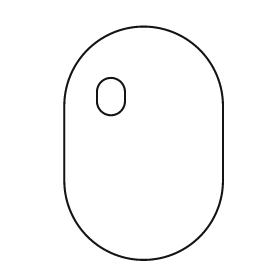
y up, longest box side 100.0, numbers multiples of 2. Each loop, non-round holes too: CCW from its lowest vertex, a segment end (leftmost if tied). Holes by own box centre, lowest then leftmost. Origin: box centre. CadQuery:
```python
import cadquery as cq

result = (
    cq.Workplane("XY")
    .moveTo(-34.0, -16.0)
    .threePointArc((0.0, -50.0), (34.0, -16.0))
    .lineTo(34.0, 16.0)
    .threePointArc((0.0, 50.0), (-34.0, 16.0))
    .close()
    .moveTo(-20.0, 18.0)
    .threePointArc((-14.0, 12.0), (-8.0, 18.0))
    .lineTo(-8.0, 22.0)
    .threePointArc((-14.0, 28.0), (-20.0, 22.0))
    .close()
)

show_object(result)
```